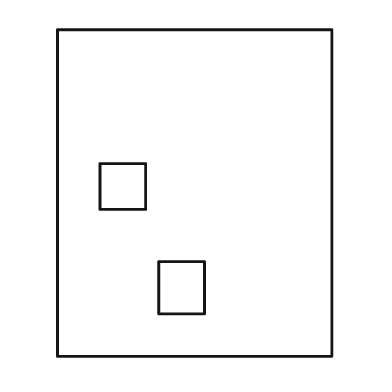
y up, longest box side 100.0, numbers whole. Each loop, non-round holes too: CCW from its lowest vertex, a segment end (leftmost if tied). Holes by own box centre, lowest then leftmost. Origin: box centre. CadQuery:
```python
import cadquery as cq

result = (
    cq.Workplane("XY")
    .moveTo(-42.0, -50.0)
    .lineTo(42.0, -50.0)
    .lineTo(42.0, 50.0)
    .lineTo(-42.0, 50.0)
    .close()
    .moveTo(-11.0, -37.0)
    .lineTo(3.0, -37.0)
    .lineTo(3.0, -21.0)
    .lineTo(-11.0, -21.0)
    .close()
    .moveTo(-29.0, -5.0)
    .lineTo(-15.0, -5.0)
    .lineTo(-15.0, 9.0)
    .lineTo(-29.0, 9.0)
    .close()
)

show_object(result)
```